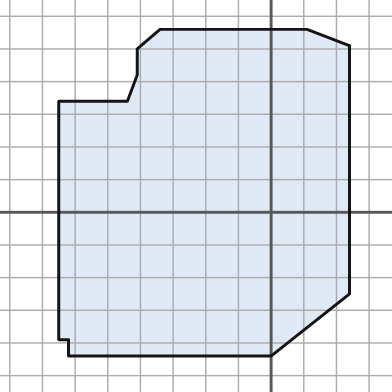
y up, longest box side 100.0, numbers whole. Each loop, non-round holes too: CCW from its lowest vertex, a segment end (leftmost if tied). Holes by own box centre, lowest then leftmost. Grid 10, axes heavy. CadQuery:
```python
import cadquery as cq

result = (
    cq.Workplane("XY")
    .moveTo(-62.0, -44.0)
    .lineTo(0.0, -44.0)
    .lineTo(24.0, -25.0)
    .lineTo(24.0, 51.0)
    .lineTo(11.0, 56.0)
    .lineTo(-34.0, 56.0)
    .lineTo(-41.0, 50.0)
    .lineTo(-41.0, 42.0)
    .lineTo(-44.0, 34.0)
    .lineTo(-65.0, 34.0)
    .lineTo(-65.0, -39.0)
    .lineTo(-62.0, -39.0)
    .close()
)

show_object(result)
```